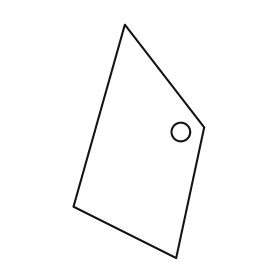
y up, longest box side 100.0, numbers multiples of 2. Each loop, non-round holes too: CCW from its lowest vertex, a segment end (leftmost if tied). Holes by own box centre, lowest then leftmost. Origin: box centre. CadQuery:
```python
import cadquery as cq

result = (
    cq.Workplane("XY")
    .moveTo(16.0, -50.0)
    .lineTo(28.0, 6.0)
    .lineTo(-6.0, 50.0)
    .lineTo(-28.0, -28.0)
    .close()
    .moveTo(18.0, 4.0)
    .circle(4.0)
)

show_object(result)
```